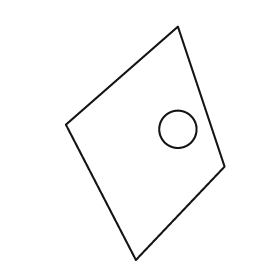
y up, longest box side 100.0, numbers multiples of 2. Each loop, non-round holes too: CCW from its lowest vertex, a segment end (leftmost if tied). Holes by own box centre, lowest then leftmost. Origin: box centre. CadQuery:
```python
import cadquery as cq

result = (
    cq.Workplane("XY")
    .moveTo(-4.0, -50.0)
    .lineTo(34.0, -10.0)
    .lineTo(14.0, 50.0)
    .lineTo(-34.0, 8.0)
    .close()
    .moveTo(14.0, 6.0)
    .circle(8.0)
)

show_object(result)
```